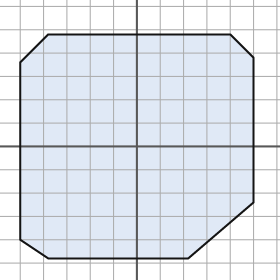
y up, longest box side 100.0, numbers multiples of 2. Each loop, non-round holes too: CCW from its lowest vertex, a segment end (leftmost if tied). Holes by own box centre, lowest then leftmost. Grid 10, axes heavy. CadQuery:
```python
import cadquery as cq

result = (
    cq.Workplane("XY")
    .moveTo(-38.0, -48.0)
    .lineTo(22.0, -48.0)
    .lineTo(50.0, -24.0)
    .lineTo(50.0, 38.0)
    .lineTo(40.0, 48.0)
    .lineTo(-38.0, 48.0)
    .lineTo(-50.0, 36.0)
    .lineTo(-50.0, -40.0)
    .close()
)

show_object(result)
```